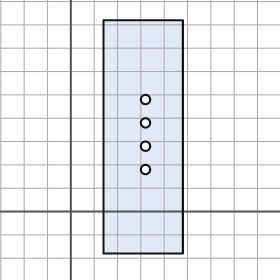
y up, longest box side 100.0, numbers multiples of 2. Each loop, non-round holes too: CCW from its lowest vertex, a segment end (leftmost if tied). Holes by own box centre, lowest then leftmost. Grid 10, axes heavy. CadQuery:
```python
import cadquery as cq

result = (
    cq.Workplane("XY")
    .moveTo(14.0, -18.0)
    .lineTo(48.0, -18.0)
    .lineTo(48.0, 82.0)
    .lineTo(14.0, 82.0)
    .close()
    .moveTo(32.0, 18.0)
    .circle(2.0)
    .moveTo(32.0, 28.0)
    .circle(2.0)
    .moveTo(32.0, 38.0)
    .circle(2.0)
    .moveTo(32.0, 48.0)
    .circle(2.0)
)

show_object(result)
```